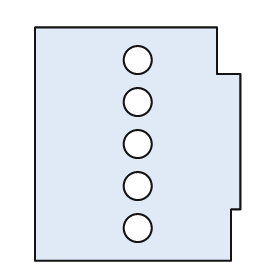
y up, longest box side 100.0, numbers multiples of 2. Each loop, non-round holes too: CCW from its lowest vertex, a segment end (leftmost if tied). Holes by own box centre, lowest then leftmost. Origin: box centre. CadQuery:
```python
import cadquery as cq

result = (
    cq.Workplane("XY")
    .moveTo(-44.0, -50.0)
    .lineTo(40.0, -50.0)
    .lineTo(40.0, -28.0)
    .lineTo(44.0, -28.0)
    .lineTo(44.0, 30.0)
    .lineTo(34.0, 30.0)
    .lineTo(34.0, 50.0)
    .lineTo(-44.0, 50.0)
    .close()
    .moveTo(0.0, -36.0)
    .circle(6.0)
    .moveTo(0.0, -18.0)
    .circle(6.0)
    .moveTo(0.0, 0.0)
    .circle(6.0)
    .moveTo(0.0, 18.0)
    .circle(6.0)
    .moveTo(0.0, 36.0)
    .circle(6.0)
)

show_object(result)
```